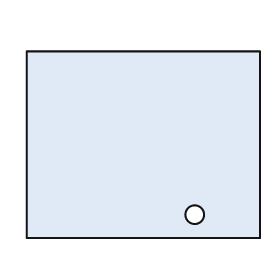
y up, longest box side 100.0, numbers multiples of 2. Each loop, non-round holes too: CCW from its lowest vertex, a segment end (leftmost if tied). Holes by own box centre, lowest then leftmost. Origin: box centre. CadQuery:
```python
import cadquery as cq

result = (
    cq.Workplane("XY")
    .moveTo(-50.0, -40.0)
    .lineTo(50.0, -40.0)
    .lineTo(50.0, 40.0)
    .lineTo(-50.0, 40.0)
    .close()
    .moveTo(22.0, -30.0)
    .circle(4.0)
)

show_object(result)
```